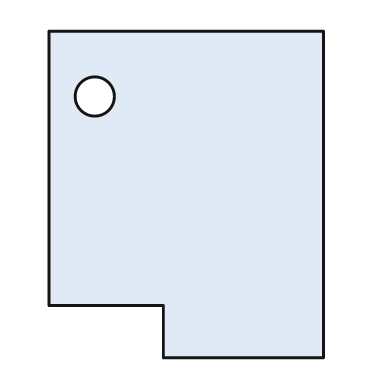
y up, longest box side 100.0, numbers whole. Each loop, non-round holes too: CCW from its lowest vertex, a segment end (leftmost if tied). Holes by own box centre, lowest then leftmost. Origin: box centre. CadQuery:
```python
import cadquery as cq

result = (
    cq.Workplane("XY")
    .moveTo(-7.0, -50.0)
    .lineTo(42.0, -50.0)
    .lineTo(42.0, 50.0)
    .lineTo(-42.0, 50.0)
    .lineTo(-42.0, -34.0)
    .lineTo(-7.0, -34.0)
    .close()
    .moveTo(-28.0, 30.0)
    .circle(6.0)
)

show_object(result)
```